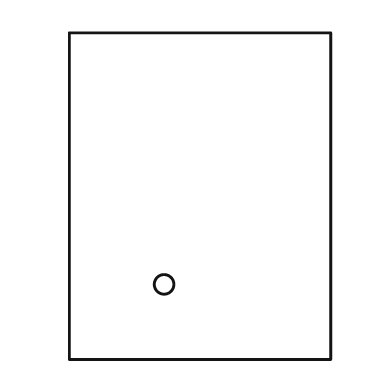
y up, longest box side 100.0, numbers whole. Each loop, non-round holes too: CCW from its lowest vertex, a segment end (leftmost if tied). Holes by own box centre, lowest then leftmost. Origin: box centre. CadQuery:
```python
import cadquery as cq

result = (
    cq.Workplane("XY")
    .moveTo(-40.0, -50.0)
    .lineTo(40.0, -50.0)
    .lineTo(40.0, 50.0)
    .lineTo(-40.0, 50.0)
    .close()
    .moveTo(-11.0, -27.0)
    .circle(3.0)
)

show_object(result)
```